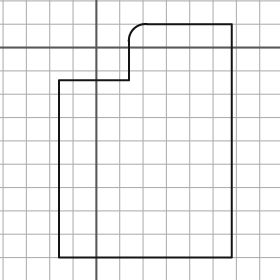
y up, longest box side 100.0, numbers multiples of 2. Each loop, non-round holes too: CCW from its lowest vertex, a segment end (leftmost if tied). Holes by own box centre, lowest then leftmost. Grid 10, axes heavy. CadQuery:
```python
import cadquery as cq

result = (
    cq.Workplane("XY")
    .moveTo(-16.0, -90.0)
    .lineTo(58.0, -90.0)
    .lineTo(58.0, 10.0)
    .lineTo(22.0, 10.0)
    .threePointArc((16.0, 8.0), (14.0, 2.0))
    .lineTo(14.0, -14.0)
    .lineTo(-16.0, -14.0)
    .close()
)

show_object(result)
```